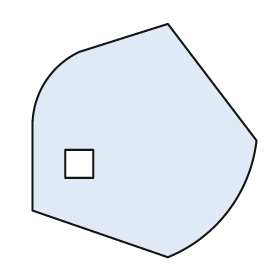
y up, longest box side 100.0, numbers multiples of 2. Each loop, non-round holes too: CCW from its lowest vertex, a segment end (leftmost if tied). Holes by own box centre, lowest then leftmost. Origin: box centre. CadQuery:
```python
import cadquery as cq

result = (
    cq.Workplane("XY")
    .moveTo(10.0, -50.0)
    .threePointArc((36.0, -30.0), (48.0, 0.0))
    .lineTo(10.0, 50.0)
    .lineTo(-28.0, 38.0)
    .threePointArc((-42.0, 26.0), (-48.0, 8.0))
    .lineTo(-48.0, -30.0)
    .close()
    .moveTo(-34.0, -16.0)
    .lineTo(-22.0, -16.0)
    .lineTo(-22.0, -4.0)
    .lineTo(-34.0, -4.0)
    .close()
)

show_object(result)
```